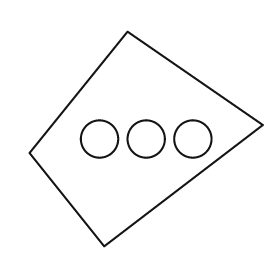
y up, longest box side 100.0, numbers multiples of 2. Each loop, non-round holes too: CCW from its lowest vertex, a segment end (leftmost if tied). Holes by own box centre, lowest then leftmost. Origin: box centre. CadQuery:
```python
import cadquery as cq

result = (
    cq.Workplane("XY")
    .moveTo(-18.0, -46.0)
    .lineTo(50.0, 6.0)
    .lineTo(-8.0, 46.0)
    .lineTo(-50.0, -6.0)
    .close()
    .moveTo(-20.0, 0.0)
    .circle(8.0)
    .moveTo(0.0, 0.0)
    .circle(8.0)
    .moveTo(20.0, 0.0)
    .circle(8.0)
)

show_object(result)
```